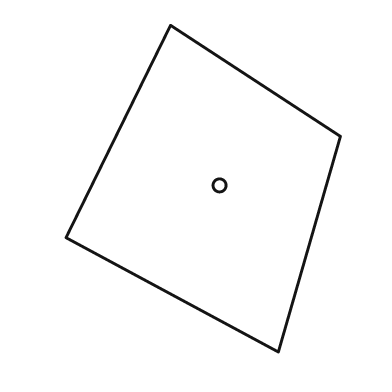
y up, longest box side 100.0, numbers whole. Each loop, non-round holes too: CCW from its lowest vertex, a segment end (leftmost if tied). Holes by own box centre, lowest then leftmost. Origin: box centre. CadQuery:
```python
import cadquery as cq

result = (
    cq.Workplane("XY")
    .moveTo(23.0, -50.0)
    .lineTo(42.0, 16.0)
    .lineTo(-10.0, 50.0)
    .lineTo(-42.0, -15.0)
    .close()
    .moveTo(5.0, 1.0)
    .circle(2.0)
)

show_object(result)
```